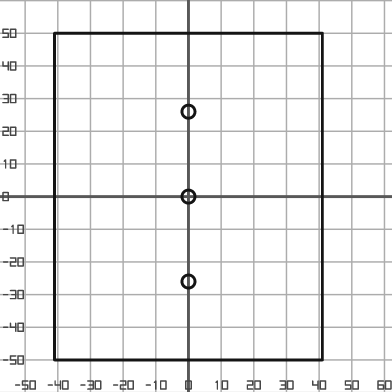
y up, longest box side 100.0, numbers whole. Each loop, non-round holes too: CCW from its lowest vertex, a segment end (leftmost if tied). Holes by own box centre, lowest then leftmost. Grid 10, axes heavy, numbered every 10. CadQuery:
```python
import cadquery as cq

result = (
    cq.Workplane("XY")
    .moveTo(-41.0, -50.0)
    .lineTo(41.0, -50.0)
    .lineTo(41.0, 50.0)
    .lineTo(-41.0, 50.0)
    .close()
    .moveTo(0.0, -26.0)
    .circle(2.0)
    .moveTo(0.0, 0.0)
    .circle(2.0)
    .moveTo(0.0, 26.0)
    .circle(2.0)
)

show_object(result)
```